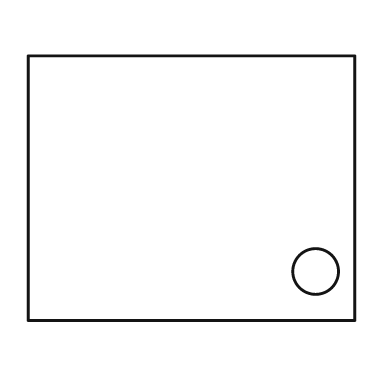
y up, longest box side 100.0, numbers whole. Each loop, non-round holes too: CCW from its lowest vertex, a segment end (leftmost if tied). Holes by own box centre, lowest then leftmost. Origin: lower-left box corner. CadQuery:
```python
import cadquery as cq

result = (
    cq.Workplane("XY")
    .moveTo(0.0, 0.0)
    .lineTo(100.0, 0.0)
    .lineTo(100.0, 81.0)
    .lineTo(0.0, 81.0)
    .close()
    .moveTo(88.0, 15.0)
    .circle(7.0)
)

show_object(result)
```